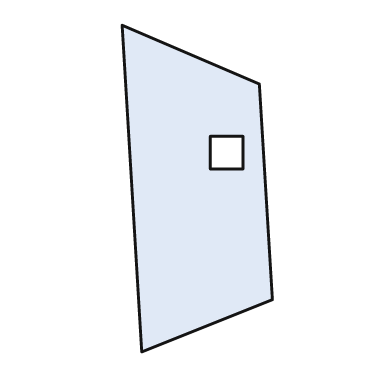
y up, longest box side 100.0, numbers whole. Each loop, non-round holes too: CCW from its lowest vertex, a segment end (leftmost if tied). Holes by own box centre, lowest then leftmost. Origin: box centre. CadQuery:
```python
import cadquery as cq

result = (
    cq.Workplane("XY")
    .moveTo(-17.0, -50.0)
    .lineTo(23.0, -34.0)
    .lineTo(19.0, 32.0)
    .lineTo(-23.0, 50.0)
    .close()
    .moveTo(4.0, 6.0)
    .lineTo(14.0, 6.0)
    .lineTo(14.0, 16.0)
    .lineTo(4.0, 16.0)
    .close()
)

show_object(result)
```